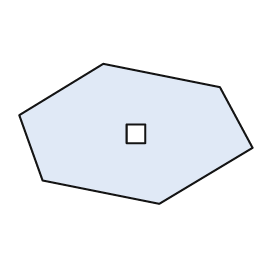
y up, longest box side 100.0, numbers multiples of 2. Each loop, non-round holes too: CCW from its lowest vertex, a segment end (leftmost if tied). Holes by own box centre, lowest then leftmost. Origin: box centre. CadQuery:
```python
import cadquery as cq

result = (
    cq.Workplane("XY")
    .moveTo(10.0, -30.0)
    .lineTo(50.0, -6.0)
    .lineTo(36.0, 20.0)
    .lineTo(-14.0, 30.0)
    .lineTo(-50.0, 8.0)
    .lineTo(-40.0, -20.0)
    .close()
    .moveTo(-4.0, -4.0)
    .lineTo(4.0, -4.0)
    .lineTo(4.0, 4.0)
    .lineTo(-4.0, 4.0)
    .close()
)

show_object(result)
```